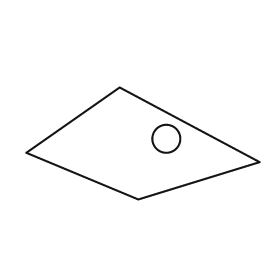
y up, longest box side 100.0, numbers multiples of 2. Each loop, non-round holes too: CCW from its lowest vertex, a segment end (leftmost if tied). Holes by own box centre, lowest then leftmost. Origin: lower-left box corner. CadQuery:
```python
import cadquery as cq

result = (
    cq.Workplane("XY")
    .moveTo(48.0, 0.0)
    .lineTo(100.0, 16.0)
    .lineTo(40.0, 48.0)
    .lineTo(0.0, 20.0)
    .close()
    .moveTo(60.0, 26.0)
    .circle(6.0)
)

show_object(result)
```